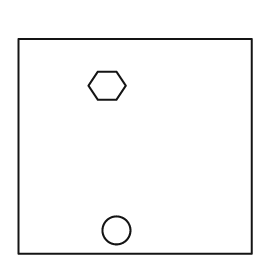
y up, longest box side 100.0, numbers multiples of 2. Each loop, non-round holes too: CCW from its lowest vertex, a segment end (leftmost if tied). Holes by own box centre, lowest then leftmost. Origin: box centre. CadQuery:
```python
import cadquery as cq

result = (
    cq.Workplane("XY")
    .moveTo(-50.0, -46.0)
    .lineTo(50.0, -46.0)
    .lineTo(50.0, 46.0)
    .lineTo(-50.0, 46.0)
    .close()
    .moveTo(-8.0, -36.0)
    .circle(6.0)
    .moveTo(-16.0, 20.0)
    .lineTo(-8.0, 20.0)
    .lineTo(-4.0, 26.0)
    .lineTo(-8.0, 32.0)
    .lineTo(-16.0, 32.0)
    .lineTo(-20.0, 26.0)
    .close()
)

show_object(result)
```